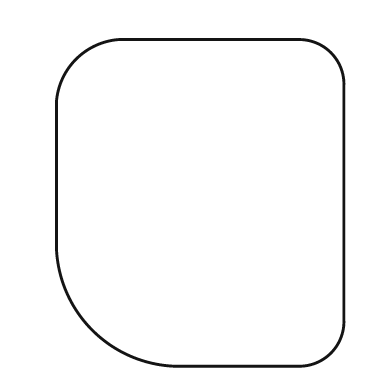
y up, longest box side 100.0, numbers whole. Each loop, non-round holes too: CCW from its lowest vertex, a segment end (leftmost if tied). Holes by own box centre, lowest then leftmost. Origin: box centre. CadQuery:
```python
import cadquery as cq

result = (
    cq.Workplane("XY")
    .moveTo(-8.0, -50.0)
    .lineTo(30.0, -50.0)
    .threePointArc((40.0, -46.0), (44.0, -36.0))
    .lineTo(44.0, 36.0)
    .threePointArc((40.0, 46.0), (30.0, 50.0))
    .lineTo(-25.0, 50.0)
    .threePointArc((-38.0, 44.0), (-44.0, 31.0))
    .lineTo(-44.0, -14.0)
    .threePointArc((-33.0, -39.0), (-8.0, -50.0))
    .close()
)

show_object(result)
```